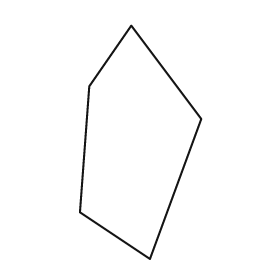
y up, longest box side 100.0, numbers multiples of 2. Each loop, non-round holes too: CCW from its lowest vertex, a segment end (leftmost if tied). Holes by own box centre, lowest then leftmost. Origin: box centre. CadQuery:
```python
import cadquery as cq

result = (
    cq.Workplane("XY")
    .moveTo(4.0, -50.0)
    .lineTo(26.0, 10.0)
    .lineTo(-4.0, 50.0)
    .lineTo(-22.0, 24.0)
    .lineTo(-26.0, -30.0)
    .close()
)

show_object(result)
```